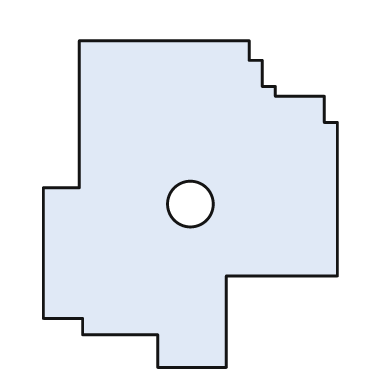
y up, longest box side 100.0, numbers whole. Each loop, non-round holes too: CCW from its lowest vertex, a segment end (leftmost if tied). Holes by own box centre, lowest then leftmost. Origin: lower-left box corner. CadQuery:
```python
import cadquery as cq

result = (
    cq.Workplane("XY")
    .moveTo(35.0, 0.0)
    .lineTo(56.0, 0.0)
    .lineTo(56.0, 28.0)
    .lineTo(90.0, 28.0)
    .lineTo(90.0, 75.0)
    .lineTo(86.0, 75.0)
    .lineTo(86.0, 83.0)
    .lineTo(71.0, 83.0)
    .lineTo(71.0, 86.0)
    .lineTo(67.0, 86.0)
    .lineTo(67.0, 94.0)
    .lineTo(63.0, 94.0)
    .lineTo(63.0, 100.0)
    .lineTo(11.0, 100.0)
    .lineTo(11.0, 55.0)
    .lineTo(0.0, 55.0)
    .lineTo(0.0, 15.0)
    .lineTo(12.0, 15.0)
    .lineTo(12.0, 10.0)
    .lineTo(35.0, 10.0)
    .close()
    .moveTo(45.0, 50.0)
    .circle(7.0)
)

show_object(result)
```